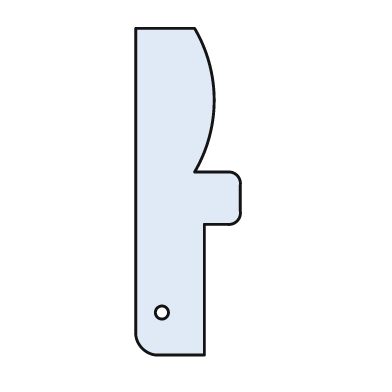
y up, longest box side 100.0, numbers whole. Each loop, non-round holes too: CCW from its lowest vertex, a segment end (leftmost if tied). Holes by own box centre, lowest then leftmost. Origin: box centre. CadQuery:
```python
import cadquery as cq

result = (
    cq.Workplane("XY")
    .moveTo(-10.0, -50.0)
    .lineTo(5.0, -50.0)
    .lineTo(5.0, -10.0)
    .lineTo(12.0, -10.0)
    .threePointArc((15.0, -9.0), (16.0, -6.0))
    .lineTo(16.0, 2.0)
    .threePointArc((15.0, 5.0), (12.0, 6.0))
    .lineTo(2.0, 6.0)
    .threePointArc((8.0, 28.0), (2.0, 50.0))
    .lineTo(-16.0, 50.0)
    .lineTo(-16.0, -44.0)
    .threePointArc((-14.0, -48.0), (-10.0, -50.0))
    .close()
    .moveTo(-8.0, -37.0)
    .circle(2.0)
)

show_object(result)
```